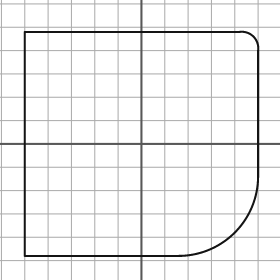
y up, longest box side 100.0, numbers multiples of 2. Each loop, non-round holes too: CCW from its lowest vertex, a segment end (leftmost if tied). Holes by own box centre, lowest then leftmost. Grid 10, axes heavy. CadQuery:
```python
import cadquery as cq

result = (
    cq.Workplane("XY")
    .moveTo(-50.0, -48.0)
    .lineTo(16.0, -48.0)
    .threePointArc((40.0, -38.0), (50.0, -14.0))
    .lineTo(50.0, 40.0)
    .threePointArc((48.0, 46.0), (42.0, 48.0))
    .lineTo(-50.0, 48.0)
    .close()
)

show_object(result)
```